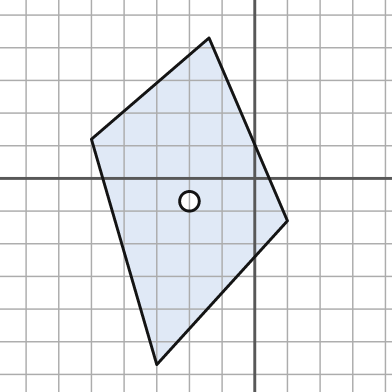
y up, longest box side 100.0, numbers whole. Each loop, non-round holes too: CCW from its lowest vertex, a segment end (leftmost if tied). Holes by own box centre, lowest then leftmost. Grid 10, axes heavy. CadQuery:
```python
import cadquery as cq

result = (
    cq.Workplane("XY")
    .moveTo(-30.0, -57.0)
    .lineTo(10.0, -13.0)
    .lineTo(-14.0, 43.0)
    .lineTo(-50.0, 12.0)
    .close()
    .moveTo(-20.0, -7.0)
    .circle(3.0)
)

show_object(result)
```